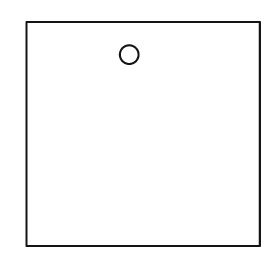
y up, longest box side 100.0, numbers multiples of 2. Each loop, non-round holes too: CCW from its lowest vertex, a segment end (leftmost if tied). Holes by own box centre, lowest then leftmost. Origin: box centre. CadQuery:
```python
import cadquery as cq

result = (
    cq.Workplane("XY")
    .moveTo(-50.0, -48.0)
    .lineTo(50.0, -48.0)
    .lineTo(50.0, 48.0)
    .lineTo(-50.0, 48.0)
    .close()
    .moveTo(-6.0, 34.0)
    .circle(4.0)
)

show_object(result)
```